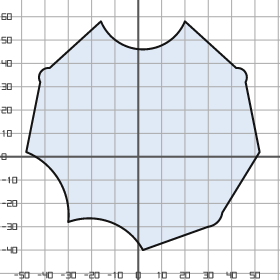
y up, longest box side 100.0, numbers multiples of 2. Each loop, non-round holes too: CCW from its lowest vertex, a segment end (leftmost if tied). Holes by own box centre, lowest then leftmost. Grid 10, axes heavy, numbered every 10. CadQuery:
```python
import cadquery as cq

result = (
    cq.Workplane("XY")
    .moveTo(2.0, -40.0)
    .lineTo(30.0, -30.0)
    .threePointArc((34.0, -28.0), (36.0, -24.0))
    .lineTo(52.0, 2.0)
    .lineTo(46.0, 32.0)
    .threePointArc((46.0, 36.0), (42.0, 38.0))
    .lineTo(20.0, 58.0)
    .threePointArc((2.0, 46.0), (-16.0, 58.0))
    .lineTo(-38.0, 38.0)
    .threePointArc((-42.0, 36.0), (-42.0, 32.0))
    .lineTo(-48.0, 2.0)
    .threePointArc((-34.0, -10.0), (-30.0, -28.0))
    .threePointArc((-12.0, -28.0), (2.0, -40.0))
    .close()
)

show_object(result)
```